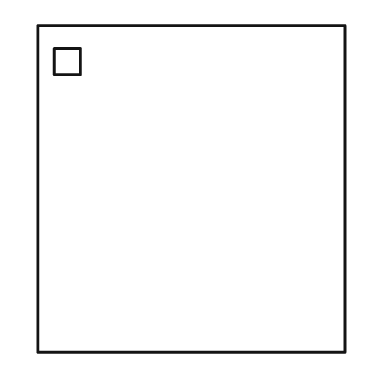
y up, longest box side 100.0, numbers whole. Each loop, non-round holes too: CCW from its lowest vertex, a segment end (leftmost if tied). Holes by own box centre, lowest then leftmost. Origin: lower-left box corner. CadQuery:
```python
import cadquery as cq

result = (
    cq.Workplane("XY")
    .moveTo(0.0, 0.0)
    .lineTo(94.0, 0.0)
    .lineTo(94.0, 100.0)
    .lineTo(0.0, 100.0)
    .close()
    .moveTo(5.0, 85.0)
    .lineTo(13.0, 85.0)
    .lineTo(13.0, 93.0)
    .lineTo(5.0, 93.0)
    .close()
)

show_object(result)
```